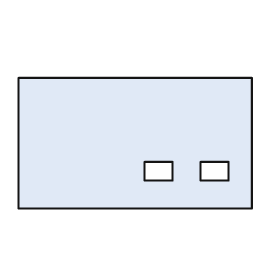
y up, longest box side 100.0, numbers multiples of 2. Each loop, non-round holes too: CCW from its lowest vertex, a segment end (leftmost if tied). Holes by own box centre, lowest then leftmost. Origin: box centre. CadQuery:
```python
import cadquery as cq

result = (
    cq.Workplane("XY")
    .moveTo(-50.0, -28.0)
    .lineTo(50.0, -28.0)
    .lineTo(50.0, 28.0)
    .lineTo(-50.0, 28.0)
    .close()
    .moveTo(4.0, -16.0)
    .lineTo(16.0, -16.0)
    .lineTo(16.0, -8.0)
    .lineTo(4.0, -8.0)
    .close()
    .moveTo(28.0, -16.0)
    .lineTo(40.0, -16.0)
    .lineTo(40.0, -8.0)
    .lineTo(28.0, -8.0)
    .close()
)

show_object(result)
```